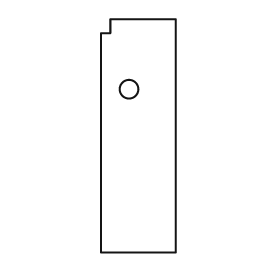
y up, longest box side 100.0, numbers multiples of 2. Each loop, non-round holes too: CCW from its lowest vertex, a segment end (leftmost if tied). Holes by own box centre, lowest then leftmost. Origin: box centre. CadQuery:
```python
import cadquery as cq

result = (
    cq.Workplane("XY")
    .moveTo(-16.0, -50.0)
    .lineTo(16.0, -50.0)
    .lineTo(16.0, 50.0)
    .lineTo(-12.0, 50.0)
    .lineTo(-12.0, 44.0)
    .lineTo(-16.0, 44.0)
    .close()
    .moveTo(-4.0, 20.0)
    .circle(4.0)
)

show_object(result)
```